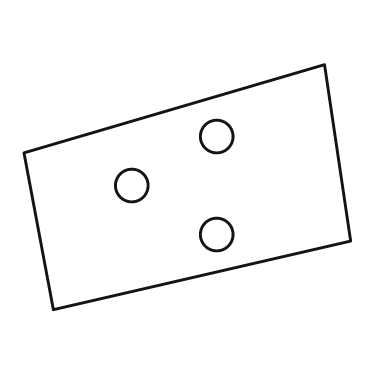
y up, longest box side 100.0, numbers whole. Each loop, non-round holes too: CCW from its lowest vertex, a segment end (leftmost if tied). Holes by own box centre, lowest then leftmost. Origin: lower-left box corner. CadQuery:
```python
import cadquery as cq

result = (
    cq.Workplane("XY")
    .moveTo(9.0, 0.0)
    .lineTo(100.0, 21.0)
    .lineTo(92.0, 75.0)
    .lineTo(0.0, 48.0)
    .close()
    .moveTo(59.0, 23.0)
    .circle(5.0)
    .moveTo(33.0, 38.0)
    .circle(5.0)
    .moveTo(59.0, 53.0)
    .circle(5.0)
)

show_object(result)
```